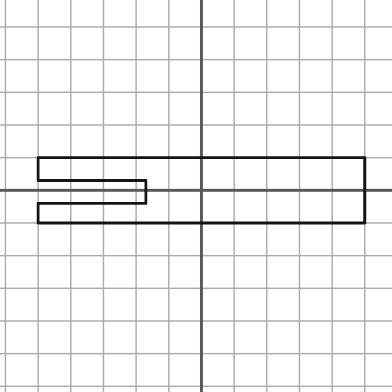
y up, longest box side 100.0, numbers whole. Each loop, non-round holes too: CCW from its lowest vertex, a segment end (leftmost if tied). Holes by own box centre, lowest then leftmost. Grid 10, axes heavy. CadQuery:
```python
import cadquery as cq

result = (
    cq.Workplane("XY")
    .moveTo(-50.0, -10.0)
    .lineTo(50.0, -10.0)
    .lineTo(50.0, 10.0)
    .lineTo(-50.0, 10.0)
    .lineTo(-50.0, 3.0)
    .lineTo(-17.0, 3.0)
    .lineTo(-17.0, -4.0)
    .lineTo(-50.0, -4.0)
    .close()
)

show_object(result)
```